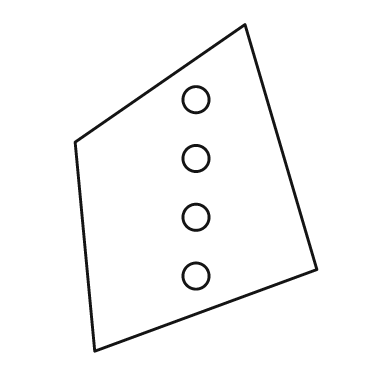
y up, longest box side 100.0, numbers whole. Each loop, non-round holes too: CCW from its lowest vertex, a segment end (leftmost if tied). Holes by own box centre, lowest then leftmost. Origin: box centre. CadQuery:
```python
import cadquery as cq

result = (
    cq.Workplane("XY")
    .moveTo(-31.0, -50.0)
    .lineTo(37.0, -25.0)
    .lineTo(15.0, 50.0)
    .lineTo(-37.0, 14.0)
    .close()
    .moveTo(0.0, -27.0)
    .circle(4.0)
    .moveTo(0.0, -9.0)
    .circle(4.0)
    .moveTo(0.0, 9.0)
    .circle(4.0)
    .moveTo(0.0, 27.0)
    .circle(4.0)
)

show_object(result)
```